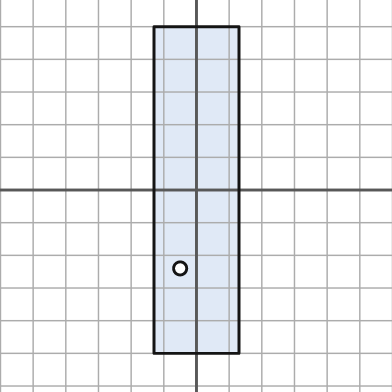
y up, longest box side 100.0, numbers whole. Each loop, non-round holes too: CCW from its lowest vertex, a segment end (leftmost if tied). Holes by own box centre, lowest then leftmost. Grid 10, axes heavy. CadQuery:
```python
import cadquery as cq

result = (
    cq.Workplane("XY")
    .moveTo(-13.0, -50.0)
    .lineTo(13.0, -50.0)
    .lineTo(13.0, 50.0)
    .lineTo(-13.0, 50.0)
    .close()
    .moveTo(-5.0, -24.0)
    .circle(2.0)
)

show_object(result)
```